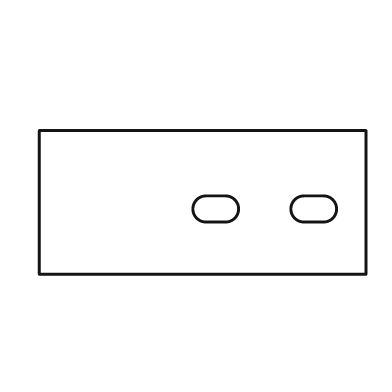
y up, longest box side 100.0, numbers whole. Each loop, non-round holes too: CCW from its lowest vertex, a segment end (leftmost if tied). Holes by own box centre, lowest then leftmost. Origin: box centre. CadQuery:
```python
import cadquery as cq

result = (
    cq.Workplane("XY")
    .moveTo(-50.0, -22.0)
    .lineTo(50.0, -22.0)
    .lineTo(50.0, 22.0)
    .lineTo(-50.0, 22.0)
    .close()
    .moveTo(1.0, -6.0)
    .lineTo(7.0, -6.0)
    .threePointArc((11.0, -2.0), (7.0, 2.0))
    .lineTo(1.0, 2.0)
    .threePointArc((-3.0, -2.0), (1.0, -6.0))
    .close()
    .moveTo(31.0, -6.0)
    .lineTo(37.0, -6.0)
    .threePointArc((41.0, -2.0), (37.0, 2.0))
    .lineTo(31.0, 2.0)
    .threePointArc((27.0, -2.0), (31.0, -6.0))
    .close()
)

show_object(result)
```